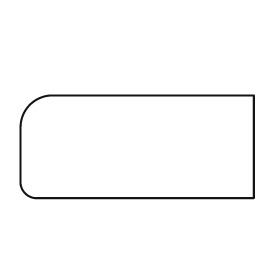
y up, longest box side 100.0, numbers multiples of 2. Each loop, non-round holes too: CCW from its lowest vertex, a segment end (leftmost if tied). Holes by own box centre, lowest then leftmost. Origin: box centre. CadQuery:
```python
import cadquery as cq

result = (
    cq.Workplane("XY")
    .moveTo(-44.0, -22.0)
    .lineTo(50.0, -22.0)
    .lineTo(50.0, 22.0)
    .lineTo(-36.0, 22.0)
    .threePointArc((-46.0, 18.0), (-50.0, 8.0))
    .lineTo(-50.0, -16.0)
    .threePointArc((-48.0, -20.0), (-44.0, -22.0))
    .close()
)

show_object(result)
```